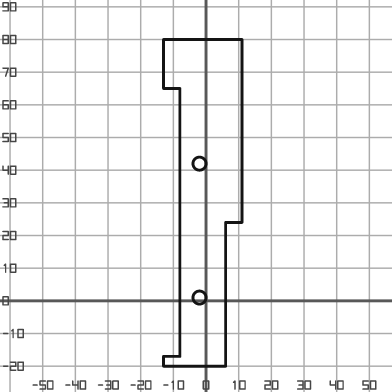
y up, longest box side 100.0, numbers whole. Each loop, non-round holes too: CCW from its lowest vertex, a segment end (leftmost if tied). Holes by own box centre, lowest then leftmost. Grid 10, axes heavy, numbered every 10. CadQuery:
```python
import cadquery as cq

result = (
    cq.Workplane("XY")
    .moveTo(-13.0, -20.0)
    .lineTo(6.0, -20.0)
    .lineTo(6.0, 24.0)
    .lineTo(11.0, 24.0)
    .lineTo(11.0, 80.0)
    .lineTo(-13.0, 80.0)
    .lineTo(-13.0, 65.0)
    .lineTo(-8.0, 65.0)
    .lineTo(-8.0, -17.0)
    .lineTo(-13.0, -17.0)
    .close()
    .moveTo(-2.0, 1.0)
    .circle(2.0)
    .moveTo(-2.0, 42.0)
    .circle(2.0)
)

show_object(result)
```